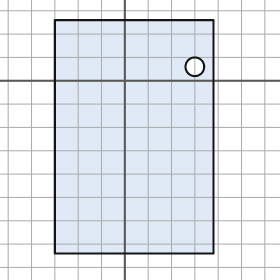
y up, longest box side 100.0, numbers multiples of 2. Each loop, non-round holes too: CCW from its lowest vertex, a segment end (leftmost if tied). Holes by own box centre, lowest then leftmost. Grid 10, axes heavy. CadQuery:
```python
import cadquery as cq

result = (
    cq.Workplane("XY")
    .moveTo(-30.0, -74.0)
    .lineTo(38.0, -74.0)
    .lineTo(38.0, 26.0)
    .lineTo(-30.0, 26.0)
    .close()
    .moveTo(30.0, 6.0)
    .circle(4.0)
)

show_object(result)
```